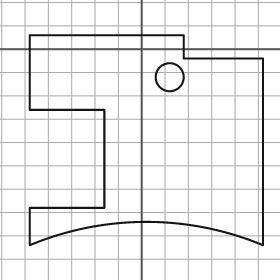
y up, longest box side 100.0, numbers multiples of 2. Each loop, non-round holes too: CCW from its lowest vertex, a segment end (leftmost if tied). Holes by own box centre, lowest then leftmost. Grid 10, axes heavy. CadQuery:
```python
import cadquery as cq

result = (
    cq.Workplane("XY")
    .moveTo(-48.0, -84.0)
    .threePointArc((2.0, -74.0), (52.0, -84.0))
    .lineTo(52.0, -4.0)
    .lineTo(18.0, -4.0)
    .lineTo(18.0, 6.0)
    .lineTo(-48.0, 6.0)
    .lineTo(-48.0, -26.0)
    .lineTo(-16.0, -26.0)
    .lineTo(-16.0, -68.0)
    .lineTo(-48.0, -68.0)
    .close()
    .moveTo(12.0, -12.0)
    .circle(6.0)
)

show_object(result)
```